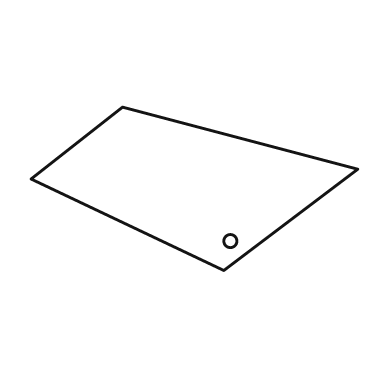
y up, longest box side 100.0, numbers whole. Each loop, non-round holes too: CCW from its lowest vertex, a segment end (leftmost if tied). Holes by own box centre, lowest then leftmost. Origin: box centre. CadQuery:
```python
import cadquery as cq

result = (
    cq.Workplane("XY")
    .moveTo(9.0, -25.0)
    .lineTo(50.0, 6.0)
    .lineTo(-22.0, 25.0)
    .lineTo(-50.0, 3.0)
    .close()
    .moveTo(11.0, -16.0)
    .circle(2.0)
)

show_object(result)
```